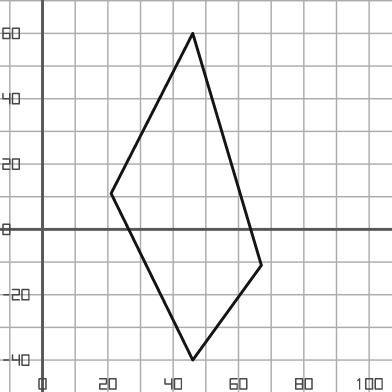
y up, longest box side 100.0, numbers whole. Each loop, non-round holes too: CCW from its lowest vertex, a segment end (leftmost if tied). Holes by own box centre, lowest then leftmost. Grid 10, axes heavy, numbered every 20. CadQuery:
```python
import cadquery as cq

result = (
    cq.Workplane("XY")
    .moveTo(46.0, -40.0)
    .lineTo(67.0, -11.0)
    .lineTo(46.0, 60.0)
    .lineTo(21.0, 11.0)
    .close()
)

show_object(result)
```